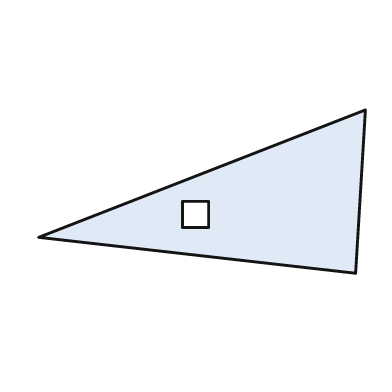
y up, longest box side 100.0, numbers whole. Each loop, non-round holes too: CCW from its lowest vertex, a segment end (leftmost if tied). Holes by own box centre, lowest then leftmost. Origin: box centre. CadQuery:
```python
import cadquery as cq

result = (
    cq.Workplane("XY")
    .moveTo(47.0, -25.0)
    .lineTo(50.0, 25.0)
    .lineTo(-50.0, -14.0)
    .close()
    .moveTo(-6.0, -11.0)
    .lineTo(2.0, -11.0)
    .lineTo(2.0, -3.0)
    .lineTo(-6.0, -3.0)
    .close()
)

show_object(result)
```